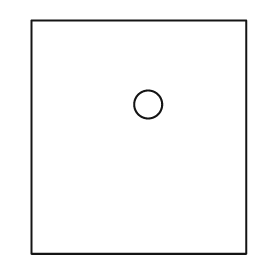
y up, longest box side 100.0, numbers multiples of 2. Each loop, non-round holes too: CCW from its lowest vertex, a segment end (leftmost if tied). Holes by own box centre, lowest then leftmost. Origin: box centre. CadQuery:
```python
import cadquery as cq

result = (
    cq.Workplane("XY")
    .moveTo(-46.0, -50.0)
    .lineTo(46.0, -50.0)
    .lineTo(46.0, 50.0)
    .lineTo(-46.0, 50.0)
    .close()
    .moveTo(4.0, 14.0)
    .circle(6.0)
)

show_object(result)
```